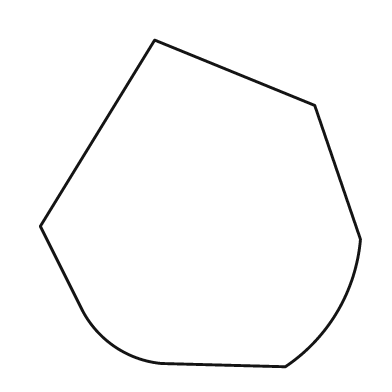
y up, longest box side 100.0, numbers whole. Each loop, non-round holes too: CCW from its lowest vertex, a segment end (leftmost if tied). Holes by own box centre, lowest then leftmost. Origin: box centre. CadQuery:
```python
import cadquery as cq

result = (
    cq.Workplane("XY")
    .moveTo(26.0, -50.0)
    .threePointArc((42.0, -33.0), (49.0, -11.0))
    .lineTo(35.0, 30.0)
    .lineTo(-14.0, 50.0)
    .lineTo(-49.0, -7.0)
    .lineTo(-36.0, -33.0)
    .threePointArc((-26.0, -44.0), (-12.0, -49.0))
    .close()
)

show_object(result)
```